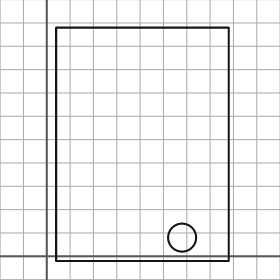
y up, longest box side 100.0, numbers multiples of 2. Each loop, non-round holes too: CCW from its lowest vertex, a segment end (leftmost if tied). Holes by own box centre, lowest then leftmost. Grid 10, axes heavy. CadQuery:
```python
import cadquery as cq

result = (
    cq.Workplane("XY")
    .moveTo(4.0, -2.0)
    .lineTo(78.0, -2.0)
    .lineTo(78.0, 98.0)
    .lineTo(4.0, 98.0)
    .close()
    .moveTo(58.0, 8.0)
    .circle(6.0)
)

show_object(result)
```